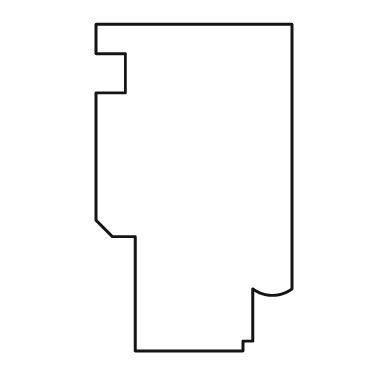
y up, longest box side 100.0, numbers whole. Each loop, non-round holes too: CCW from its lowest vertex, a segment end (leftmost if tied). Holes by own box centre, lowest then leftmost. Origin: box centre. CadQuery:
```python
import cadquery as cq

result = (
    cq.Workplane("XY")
    .moveTo(-18.0, -50.0)
    .lineTo(15.0, -50.0)
    .lineTo(15.0, -47.0)
    .lineTo(18.0, -47.0)
    .lineTo(18.0, -31.0)
    .threePointArc((24.0, -33.0), (30.0, -31.0))
    .lineTo(30.0, 50.0)
    .lineTo(-30.0, 50.0)
    .lineTo(-30.0, 41.0)
    .lineTo(-21.0, 41.0)
    .lineTo(-21.0, 29.0)
    .lineTo(-30.0, 29.0)
    .lineTo(-30.0, -10.0)
    .lineTo(-25.0, -15.0)
    .lineTo(-18.0, -15.0)
    .close()
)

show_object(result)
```